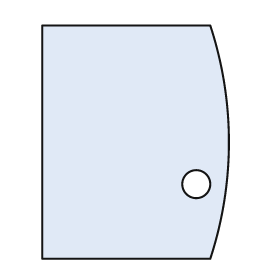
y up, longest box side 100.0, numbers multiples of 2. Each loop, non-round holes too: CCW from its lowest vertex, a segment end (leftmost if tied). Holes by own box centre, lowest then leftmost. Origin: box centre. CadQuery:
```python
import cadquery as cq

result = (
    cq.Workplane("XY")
    .moveTo(-40.0, -50.0)
    .lineTo(32.0, -50.0)
    .threePointArc((40.0, 0.0), (32.0, 50.0))
    .lineTo(-40.0, 50.0)
    .close()
    .moveTo(26.0, -18.0)
    .circle(6.0)
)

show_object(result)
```